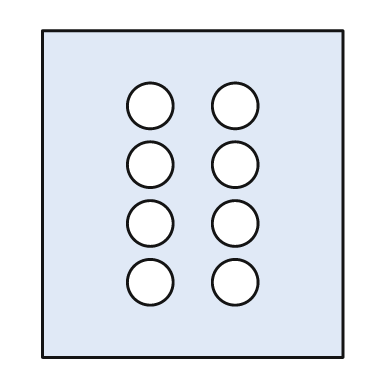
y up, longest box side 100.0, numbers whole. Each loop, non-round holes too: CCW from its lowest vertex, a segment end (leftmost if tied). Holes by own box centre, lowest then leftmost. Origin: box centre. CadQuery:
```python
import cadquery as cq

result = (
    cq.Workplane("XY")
    .moveTo(-46.0, -50.0)
    .lineTo(46.0, -50.0)
    .lineTo(46.0, 50.0)
    .lineTo(-46.0, 50.0)
    .close()
    .moveTo(-13.0, -27.0)
    .circle(7.0)
    .moveTo(13.0, -27.0)
    .circle(7.0)
    .moveTo(-13.0, -9.0)
    .circle(7.0)
    .moveTo(13.0, -9.0)
    .circle(7.0)
    .moveTo(-13.0, 9.0)
    .circle(7.0)
    .moveTo(13.0, 9.0)
    .circle(7.0)
    .moveTo(-13.0, 27.0)
    .circle(7.0)
    .moveTo(13.0, 27.0)
    .circle(7.0)
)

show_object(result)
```